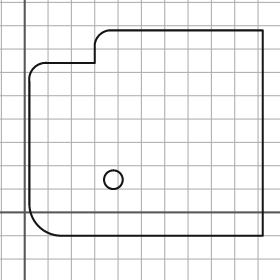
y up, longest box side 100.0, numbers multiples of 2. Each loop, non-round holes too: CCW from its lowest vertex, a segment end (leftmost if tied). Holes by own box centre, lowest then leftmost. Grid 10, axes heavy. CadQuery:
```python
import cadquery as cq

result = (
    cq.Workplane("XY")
    .moveTo(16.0, -10.0)
    .lineTo(102.0, -10.0)
    .lineTo(102.0, 78.0)
    .lineTo(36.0, 78.0)
    .threePointArc((32.0, 76.0), (30.0, 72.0))
    .lineTo(30.0, 64.0)
    .lineTo(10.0, 64.0)
    .threePointArc((4.0, 62.0), (2.0, 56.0))
    .lineTo(2.0, 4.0)
    .threePointArc((6.0, -6.0), (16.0, -10.0))
    .close()
    .moveTo(38.0, 14.0)
    .circle(4.0)
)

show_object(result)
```